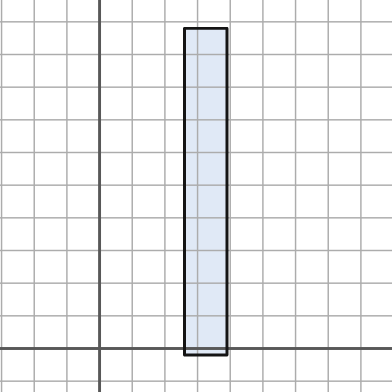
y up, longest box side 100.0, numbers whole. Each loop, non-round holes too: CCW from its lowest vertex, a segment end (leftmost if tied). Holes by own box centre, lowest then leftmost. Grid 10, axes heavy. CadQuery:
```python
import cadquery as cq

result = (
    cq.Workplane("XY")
    .moveTo(26.0, -2.0)
    .lineTo(39.0, -2.0)
    .lineTo(39.0, 98.0)
    .lineTo(26.0, 98.0)
    .close()
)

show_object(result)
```